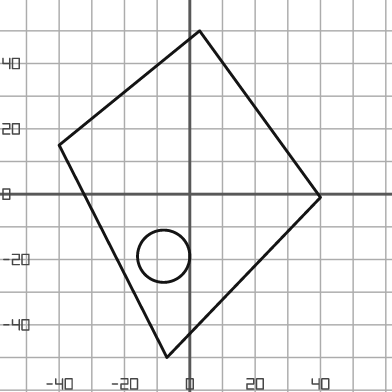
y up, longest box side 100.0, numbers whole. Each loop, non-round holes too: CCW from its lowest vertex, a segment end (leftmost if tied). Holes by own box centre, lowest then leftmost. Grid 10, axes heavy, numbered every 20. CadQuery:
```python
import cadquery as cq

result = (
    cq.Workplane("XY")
    .moveTo(-7.0, -50.0)
    .lineTo(40.0, -1.0)
    .lineTo(3.0, 50.0)
    .lineTo(-40.0, 15.0)
    .close()
    .moveTo(-8.0, -19.0)
    .circle(8.0)
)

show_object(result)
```